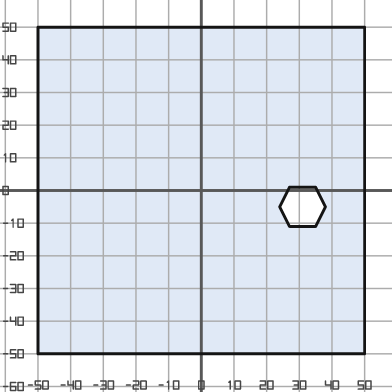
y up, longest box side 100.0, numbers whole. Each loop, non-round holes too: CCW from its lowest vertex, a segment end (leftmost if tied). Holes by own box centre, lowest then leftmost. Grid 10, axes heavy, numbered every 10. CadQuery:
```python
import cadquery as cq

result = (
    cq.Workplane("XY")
    .moveTo(-50.0, -50.0)
    .lineTo(50.0, -50.0)
    .lineTo(50.0, 50.0)
    .lineTo(-50.0, 50.0)
    .close()
    .moveTo(27.0, -11.0)
    .lineTo(35.0, -11.0)
    .lineTo(38.0, -5.0)
    .lineTo(35.0, 1.0)
    .lineTo(27.0, 1.0)
    .lineTo(24.0, -5.0)
    .close()
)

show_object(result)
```